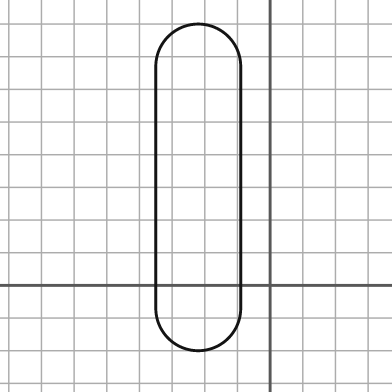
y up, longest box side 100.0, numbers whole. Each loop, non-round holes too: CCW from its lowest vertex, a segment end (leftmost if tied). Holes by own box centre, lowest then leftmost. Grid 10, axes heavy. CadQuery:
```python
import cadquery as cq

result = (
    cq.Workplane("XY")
    .moveTo(-35.0, -7.0)
    .threePointArc((-22.0, -20.0), (-9.0, -7.0))
    .lineTo(-9.0, 67.0)
    .threePointArc((-22.0, 80.0), (-35.0, 67.0))
    .close()
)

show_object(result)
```